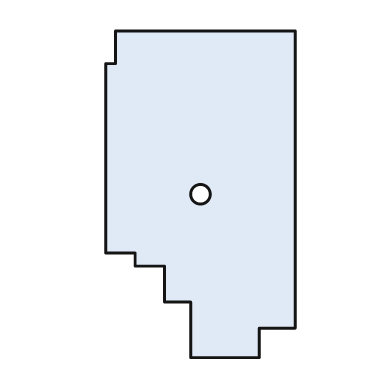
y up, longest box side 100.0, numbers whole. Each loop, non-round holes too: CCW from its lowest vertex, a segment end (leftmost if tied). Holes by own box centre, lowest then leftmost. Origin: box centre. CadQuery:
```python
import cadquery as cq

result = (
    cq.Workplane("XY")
    .moveTo(-3.0, -50.0)
    .lineTo(18.0, -50.0)
    .lineTo(18.0, -41.0)
    .lineTo(29.0, -41.0)
    .lineTo(29.0, 50.0)
    .lineTo(-26.0, 50.0)
    .lineTo(-26.0, 40.0)
    .lineTo(-29.0, 40.0)
    .lineTo(-29.0, -18.0)
    .lineTo(-20.0, -18.0)
    .lineTo(-20.0, -22.0)
    .lineTo(-11.0, -22.0)
    .lineTo(-11.0, -33.0)
    .lineTo(-3.0, -33.0)
    .close()
    .moveTo(0.0, 0.0)
    .circle(3.0)
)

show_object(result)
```